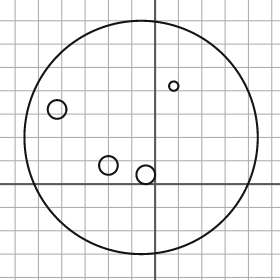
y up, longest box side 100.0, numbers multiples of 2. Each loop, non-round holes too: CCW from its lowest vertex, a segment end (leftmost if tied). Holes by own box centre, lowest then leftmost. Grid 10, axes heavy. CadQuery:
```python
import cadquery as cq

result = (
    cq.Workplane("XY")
    .moveTo(-6.0, 20.0)
    .circle(50.0)
    .moveTo(-4.0, 4.0)
    .circle(4.0)
    .moveTo(-20.0, 8.0)
    .circle(4.0)
    .moveTo(-42.0, 32.0)
    .circle(4.0)
    .moveTo(8.0, 42.0)
    .circle(2.0)
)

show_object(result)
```